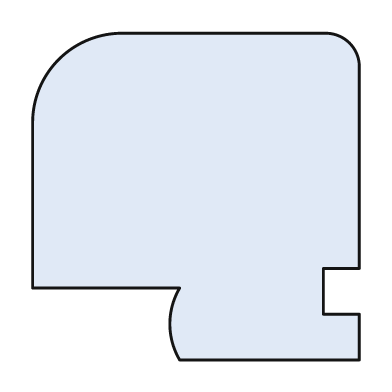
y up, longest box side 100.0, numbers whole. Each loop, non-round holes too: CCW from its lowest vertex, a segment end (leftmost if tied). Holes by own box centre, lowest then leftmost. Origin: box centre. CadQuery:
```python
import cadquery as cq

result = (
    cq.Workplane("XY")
    .moveTo(-5.0, -50.0)
    .lineTo(50.0, -50.0)
    .lineTo(50.0, -36.0)
    .lineTo(39.0, -36.0)
    .lineTo(39.0, -22.0)
    .lineTo(50.0, -22.0)
    .lineTo(50.0, 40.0)
    .threePointArc((47.0, 47.0), (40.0, 50.0))
    .lineTo(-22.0, 50.0)
    .threePointArc((-42.0, 42.0), (-50.0, 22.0))
    .lineTo(-50.0, -28.0)
    .lineTo(-5.0, -28.0)
    .threePointArc((-8.0, -39.0), (-5.0, -50.0))
    .close()
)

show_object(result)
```